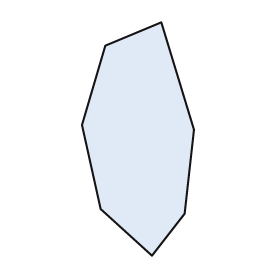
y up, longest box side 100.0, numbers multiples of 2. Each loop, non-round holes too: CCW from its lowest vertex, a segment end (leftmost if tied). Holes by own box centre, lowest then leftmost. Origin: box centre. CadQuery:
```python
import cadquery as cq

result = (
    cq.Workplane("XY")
    .moveTo(6.0, -50.0)
    .lineTo(20.0, -32.0)
    .lineTo(24.0, 4.0)
    .lineTo(10.0, 50.0)
    .lineTo(-14.0, 40.0)
    .lineTo(-24.0, 6.0)
    .lineTo(-16.0, -30.0)
    .close()
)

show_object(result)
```